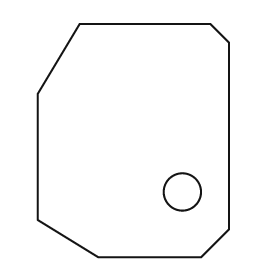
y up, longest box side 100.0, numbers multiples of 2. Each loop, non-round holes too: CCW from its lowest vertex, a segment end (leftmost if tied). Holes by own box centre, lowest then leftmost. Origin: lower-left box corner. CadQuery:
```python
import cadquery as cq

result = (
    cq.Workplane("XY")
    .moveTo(26.0, 0.0)
    .lineTo(70.0, 0.0)
    .lineTo(82.0, 12.0)
    .lineTo(82.0, 92.0)
    .lineTo(74.0, 100.0)
    .lineTo(18.0, 100.0)
    .lineTo(0.0, 70.0)
    .lineTo(0.0, 16.0)
    .close()
    .moveTo(62.0, 28.0)
    .circle(8.0)
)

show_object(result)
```